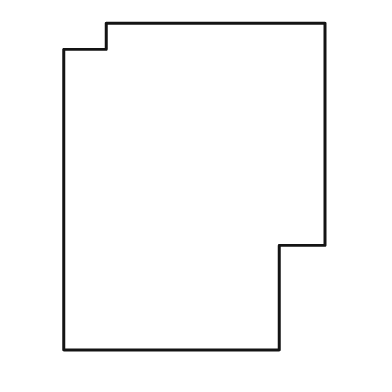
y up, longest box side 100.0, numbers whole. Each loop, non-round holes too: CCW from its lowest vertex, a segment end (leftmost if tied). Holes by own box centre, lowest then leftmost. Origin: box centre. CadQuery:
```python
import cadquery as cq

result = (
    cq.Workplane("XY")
    .moveTo(-40.0, -50.0)
    .lineTo(26.0, -50.0)
    .lineTo(26.0, -18.0)
    .lineTo(40.0, -18.0)
    .lineTo(40.0, 50.0)
    .lineTo(-27.0, 50.0)
    .lineTo(-27.0, 42.0)
    .lineTo(-40.0, 42.0)
    .close()
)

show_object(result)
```